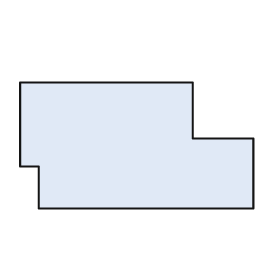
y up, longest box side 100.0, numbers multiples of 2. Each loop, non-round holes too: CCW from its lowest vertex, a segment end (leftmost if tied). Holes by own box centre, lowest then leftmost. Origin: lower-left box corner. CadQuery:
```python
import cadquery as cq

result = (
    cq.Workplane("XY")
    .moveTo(8.0, 0.0)
    .lineTo(100.0, 0.0)
    .lineTo(100.0, 30.0)
    .lineTo(74.0, 30.0)
    .lineTo(74.0, 54.0)
    .lineTo(0.0, 54.0)
    .lineTo(0.0, 18.0)
    .lineTo(8.0, 18.0)
    .close()
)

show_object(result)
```